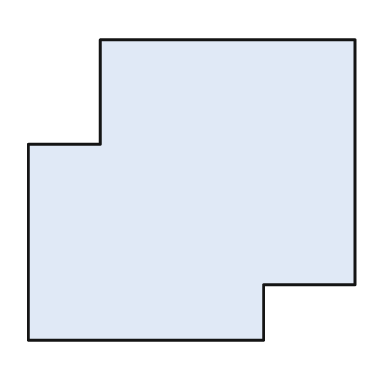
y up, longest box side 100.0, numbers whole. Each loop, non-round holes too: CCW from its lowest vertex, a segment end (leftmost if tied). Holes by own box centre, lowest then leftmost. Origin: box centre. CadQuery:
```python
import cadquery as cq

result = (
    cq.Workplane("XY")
    .moveTo(-50.0, -46.0)
    .lineTo(22.0, -46.0)
    .lineTo(22.0, -29.0)
    .lineTo(50.0, -29.0)
    .lineTo(50.0, 46.0)
    .lineTo(-28.0, 46.0)
    .lineTo(-28.0, 14.0)
    .lineTo(-50.0, 14.0)
    .close()
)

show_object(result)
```